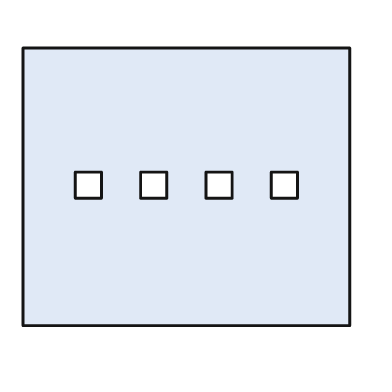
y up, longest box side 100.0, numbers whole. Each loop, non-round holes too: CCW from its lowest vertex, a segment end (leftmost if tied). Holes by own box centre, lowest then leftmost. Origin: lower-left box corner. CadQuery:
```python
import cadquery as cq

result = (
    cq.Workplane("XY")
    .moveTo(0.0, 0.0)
    .lineTo(100.0, 0.0)
    .lineTo(100.0, 85.0)
    .lineTo(0.0, 85.0)
    .close()
    .moveTo(16.0, 39.0)
    .lineTo(24.0, 39.0)
    .lineTo(24.0, 47.0)
    .lineTo(16.0, 47.0)
    .close()
    .moveTo(36.0, 39.0)
    .lineTo(44.0, 39.0)
    .lineTo(44.0, 47.0)
    .lineTo(36.0, 47.0)
    .close()
    .moveTo(56.0, 39.0)
    .lineTo(64.0, 39.0)
    .lineTo(64.0, 47.0)
    .lineTo(56.0, 47.0)
    .close()
    .moveTo(76.0, 39.0)
    .lineTo(84.0, 39.0)
    .lineTo(84.0, 47.0)
    .lineTo(76.0, 47.0)
    .close()
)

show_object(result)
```